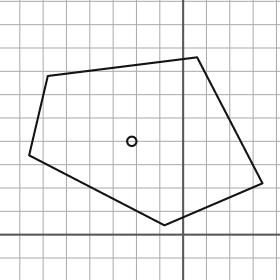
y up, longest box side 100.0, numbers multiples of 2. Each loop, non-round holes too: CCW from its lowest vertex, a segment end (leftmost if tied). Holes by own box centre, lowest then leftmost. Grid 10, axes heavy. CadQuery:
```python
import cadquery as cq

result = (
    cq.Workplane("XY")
    .moveTo(-8.0, 4.0)
    .lineTo(34.0, 22.0)
    .lineTo(6.0, 76.0)
    .lineTo(-58.0, 68.0)
    .lineTo(-66.0, 34.0)
    .close()
    .moveTo(-22.0, 40.0)
    .circle(2.0)
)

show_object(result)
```